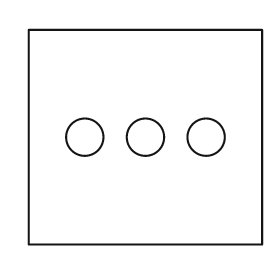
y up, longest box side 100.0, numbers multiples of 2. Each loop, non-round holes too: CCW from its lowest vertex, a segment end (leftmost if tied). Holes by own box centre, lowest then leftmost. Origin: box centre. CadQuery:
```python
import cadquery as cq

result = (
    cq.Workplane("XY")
    .moveTo(-50.0, -46.0)
    .lineTo(50.0, -46.0)
    .lineTo(50.0, 46.0)
    .lineTo(-50.0, 46.0)
    .close()
    .moveTo(-26.0, 0.0)
    .circle(8.0)
    .moveTo(0.0, 0.0)
    .circle(8.0)
    .moveTo(26.0, 0.0)
    .circle(8.0)
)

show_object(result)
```